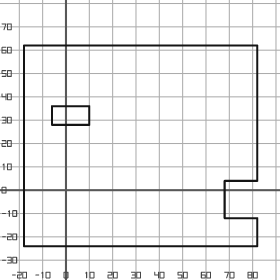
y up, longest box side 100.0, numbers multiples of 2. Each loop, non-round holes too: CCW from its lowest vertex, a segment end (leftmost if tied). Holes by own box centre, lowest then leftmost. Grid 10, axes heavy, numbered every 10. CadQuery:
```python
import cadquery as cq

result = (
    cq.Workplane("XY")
    .moveTo(-18.0, -24.0)
    .lineTo(82.0, -24.0)
    .lineTo(82.0, -12.0)
    .lineTo(68.0, -12.0)
    .lineTo(68.0, 4.0)
    .lineTo(82.0, 4.0)
    .lineTo(82.0, 62.0)
    .lineTo(-18.0, 62.0)
    .close()
    .moveTo(-6.0, 28.0)
    .lineTo(10.0, 28.0)
    .lineTo(10.0, 36.0)
    .lineTo(-6.0, 36.0)
    .close()
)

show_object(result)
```